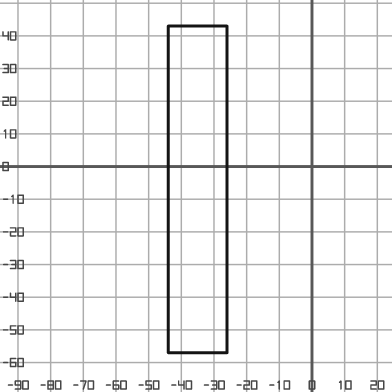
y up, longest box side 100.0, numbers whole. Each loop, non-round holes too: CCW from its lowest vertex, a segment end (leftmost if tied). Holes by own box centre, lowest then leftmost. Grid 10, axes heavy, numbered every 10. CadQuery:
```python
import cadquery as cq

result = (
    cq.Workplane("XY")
    .moveTo(-44.0, -57.0)
    .lineTo(-26.0, -57.0)
    .lineTo(-26.0, 43.0)
    .lineTo(-44.0, 43.0)
    .close()
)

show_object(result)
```